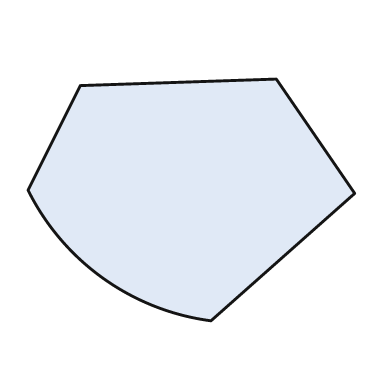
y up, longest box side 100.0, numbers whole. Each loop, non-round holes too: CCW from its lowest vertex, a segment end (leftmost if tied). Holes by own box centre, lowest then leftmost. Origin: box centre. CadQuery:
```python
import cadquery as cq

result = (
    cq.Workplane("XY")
    .moveTo(6.0, -37.0)
    .lineTo(50.0, 2.0)
    .lineTo(26.0, 37.0)
    .lineTo(-34.0, 35.0)
    .lineTo(-50.0, 3.0)
    .threePointArc((-27.0, -24.0), (6.0, -37.0))
    .close()
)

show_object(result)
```